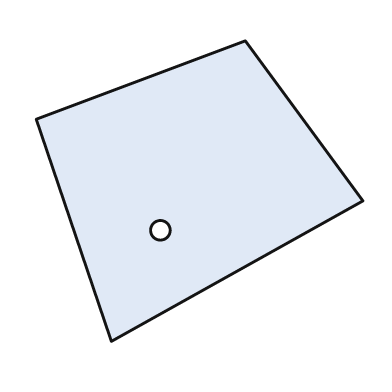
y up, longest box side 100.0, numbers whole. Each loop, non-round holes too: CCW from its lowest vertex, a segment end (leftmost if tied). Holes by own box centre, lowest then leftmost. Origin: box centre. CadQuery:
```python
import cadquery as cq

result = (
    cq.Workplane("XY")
    .moveTo(-27.0, -46.0)
    .lineTo(50.0, -3.0)
    .lineTo(14.0, 46.0)
    .lineTo(-50.0, 22.0)
    .close()
    .moveTo(-12.0, -12.0)
    .circle(3.0)
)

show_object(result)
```